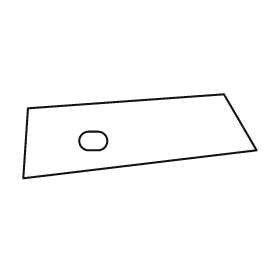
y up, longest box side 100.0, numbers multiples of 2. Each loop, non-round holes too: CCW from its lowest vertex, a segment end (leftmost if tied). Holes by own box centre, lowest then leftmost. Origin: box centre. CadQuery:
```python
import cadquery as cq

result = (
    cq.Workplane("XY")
    .moveTo(-50.0, -18.0)
    .lineTo(50.0, -6.0)
    .lineTo(36.0, 18.0)
    .lineTo(-48.0, 12.0)
    .close()
    .moveTo(-22.0, -6.0)
    .lineTo(-18.0, -6.0)
    .threePointArc((-14.0, -2.0), (-18.0, 2.0))
    .lineTo(-22.0, 2.0)
    .threePointArc((-26.0, -2.0), (-22.0, -6.0))
    .close()
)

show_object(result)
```